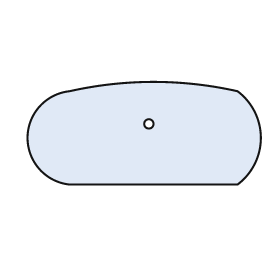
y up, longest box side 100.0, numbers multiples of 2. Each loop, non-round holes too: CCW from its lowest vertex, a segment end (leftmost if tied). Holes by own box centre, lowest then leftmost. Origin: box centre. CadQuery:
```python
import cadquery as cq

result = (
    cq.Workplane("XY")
    .moveTo(-32.0, -22.0)
    .lineTo(40.0, -22.0)
    .threePointArc((50.0, -2.0), (40.0, 18.0))
    .threePointArc((4.0, 22.0), (-32.0, 18.0))
    .threePointArc((-50.0, -2.0), (-32.0, -22.0))
    .close()
    .moveTo(2.0, 4.0)
    .circle(2.0)
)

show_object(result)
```